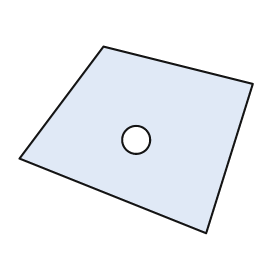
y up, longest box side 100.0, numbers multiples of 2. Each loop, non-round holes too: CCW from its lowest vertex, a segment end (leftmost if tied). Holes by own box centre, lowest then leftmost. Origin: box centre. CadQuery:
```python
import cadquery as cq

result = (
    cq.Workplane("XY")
    .moveTo(30.0, -40.0)
    .lineTo(50.0, 24.0)
    .lineTo(-14.0, 40.0)
    .lineTo(-50.0, -8.0)
    .close()
    .moveTo(0.0, 0.0)
    .circle(6.0)
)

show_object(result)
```